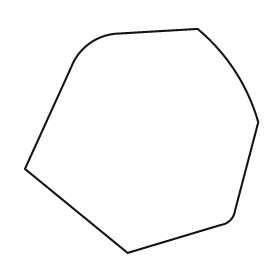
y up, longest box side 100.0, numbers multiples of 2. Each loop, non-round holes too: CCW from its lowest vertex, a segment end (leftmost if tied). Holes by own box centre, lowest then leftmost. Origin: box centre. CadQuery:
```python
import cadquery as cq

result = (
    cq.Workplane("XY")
    .moveTo(-6.0, -48.0)
    .lineTo(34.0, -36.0)
    .threePointArc((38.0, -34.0), (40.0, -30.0))
    .lineTo(50.0, 8.0)
    .threePointArc((40.0, 30.0), (24.0, 48.0))
    .lineTo(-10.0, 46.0)
    .threePointArc((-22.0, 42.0), (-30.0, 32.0))
    .lineTo(-50.0, -12.0)
    .close()
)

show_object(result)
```